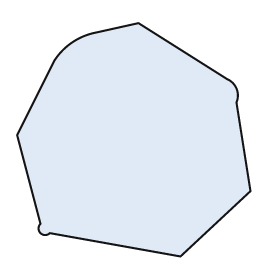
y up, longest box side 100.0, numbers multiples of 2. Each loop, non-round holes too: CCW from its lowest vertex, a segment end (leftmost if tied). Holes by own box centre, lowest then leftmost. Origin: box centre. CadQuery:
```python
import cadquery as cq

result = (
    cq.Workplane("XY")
    .moveTo(20.0, -50.0)
    .lineTo(50.0, -22.0)
    .lineTo(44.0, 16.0)
    .threePointArc((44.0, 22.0), (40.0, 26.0))
    .lineTo(2.0, 50.0)
    .lineTo(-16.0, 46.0)
    .threePointArc((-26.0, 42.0), (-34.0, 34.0))
    .lineTo(-50.0, 2.0)
    .lineTo(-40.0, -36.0)
    .threePointArc((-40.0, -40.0), (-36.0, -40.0))
    .close()
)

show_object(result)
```